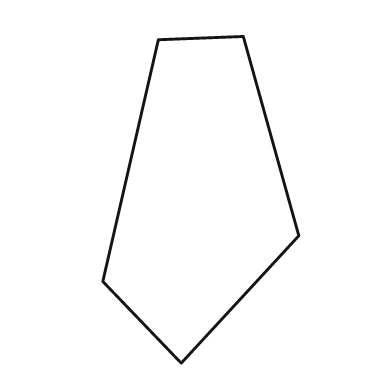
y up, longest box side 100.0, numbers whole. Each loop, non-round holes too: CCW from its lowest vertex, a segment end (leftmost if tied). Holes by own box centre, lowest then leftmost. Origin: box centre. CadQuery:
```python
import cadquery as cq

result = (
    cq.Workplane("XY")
    .moveTo(-6.0, -50.0)
    .lineTo(30.0, -11.0)
    .lineTo(13.0, 50.0)
    .lineTo(-13.0, 49.0)
    .lineTo(-30.0, -25.0)
    .close()
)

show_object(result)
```